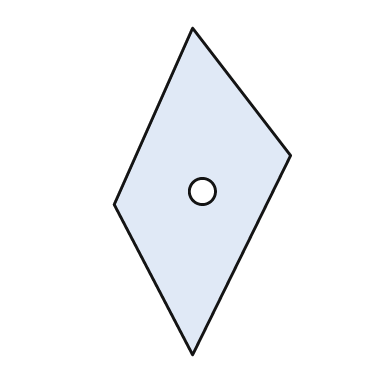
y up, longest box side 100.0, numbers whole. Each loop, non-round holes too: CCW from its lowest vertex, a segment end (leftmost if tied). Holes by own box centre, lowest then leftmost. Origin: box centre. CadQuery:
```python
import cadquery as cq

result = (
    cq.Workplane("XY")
    .moveTo(-3.0, -50.0)
    .lineTo(27.0, 11.0)
    .lineTo(-3.0, 50.0)
    .lineTo(-27.0, -4.0)
    .close()
    .moveTo(0.0, 0.0)
    .circle(4.0)
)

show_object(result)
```